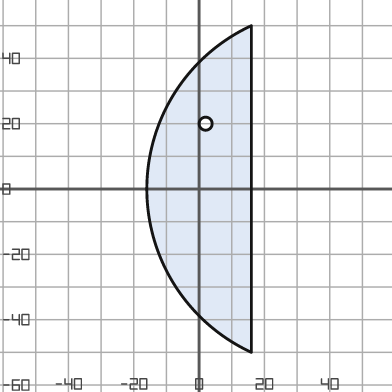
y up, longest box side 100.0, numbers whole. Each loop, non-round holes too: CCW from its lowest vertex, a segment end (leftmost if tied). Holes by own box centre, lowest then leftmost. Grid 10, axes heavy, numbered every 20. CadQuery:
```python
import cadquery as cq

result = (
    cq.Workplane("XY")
    .moveTo(16.0, -50.0)
    .lineTo(16.0, 50.0)
    .threePointArc((-16.0, 0.0), (16.0, -50.0))
    .close()
    .moveTo(2.0, 20.0)
    .circle(2.0)
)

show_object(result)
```